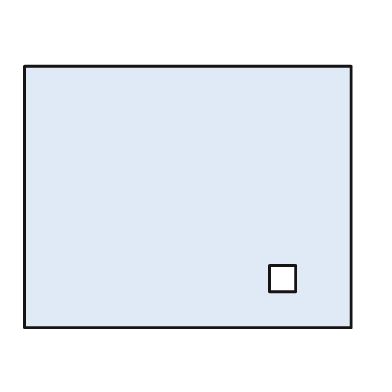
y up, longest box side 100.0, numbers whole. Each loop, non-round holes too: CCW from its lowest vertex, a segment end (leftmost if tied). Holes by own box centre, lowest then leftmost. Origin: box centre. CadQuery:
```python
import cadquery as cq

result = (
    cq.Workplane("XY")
    .moveTo(-50.0, -40.0)
    .lineTo(50.0, -40.0)
    .lineTo(50.0, 40.0)
    .lineTo(-50.0, 40.0)
    .close()
    .moveTo(25.0, -29.0)
    .lineTo(33.0, -29.0)
    .lineTo(33.0, -21.0)
    .lineTo(25.0, -21.0)
    .close()
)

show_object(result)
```